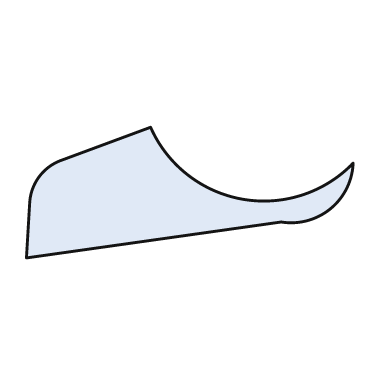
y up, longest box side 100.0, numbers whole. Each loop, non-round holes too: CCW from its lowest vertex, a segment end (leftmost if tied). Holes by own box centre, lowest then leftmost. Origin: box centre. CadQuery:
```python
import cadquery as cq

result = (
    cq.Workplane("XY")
    .moveTo(-50.0, -20.0)
    .lineTo(28.0, -9.0)
    .threePointArc((43.0, -5.0), (50.0, 9.0))
    .threePointArc((16.0, -2.0), (-12.0, 20.0))
    .lineTo(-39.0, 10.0)
    .threePointArc((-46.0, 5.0), (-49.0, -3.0))
    .close()
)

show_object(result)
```